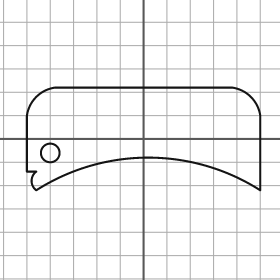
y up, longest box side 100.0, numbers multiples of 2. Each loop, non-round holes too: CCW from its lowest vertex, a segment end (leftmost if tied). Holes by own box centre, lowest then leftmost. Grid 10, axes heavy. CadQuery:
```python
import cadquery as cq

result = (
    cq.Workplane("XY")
    .moveTo(-46.0, -22.0)
    .threePointArc((2.0, -8.0), (50.0, -22.0))
    .lineTo(50.0, 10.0)
    .threePointArc((46.0, 18.0), (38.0, 22.0))
    .lineTo(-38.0, 22.0)
    .threePointArc((-46.0, 18.0), (-50.0, 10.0))
    .lineTo(-50.0, -14.0)
    .lineTo(-46.0, -14.0)
    .threePointArc((-48.0, -18.0), (-46.0, -22.0))
    .close()
    .moveTo(-40.0, -6.0)
    .circle(4.0)
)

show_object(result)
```